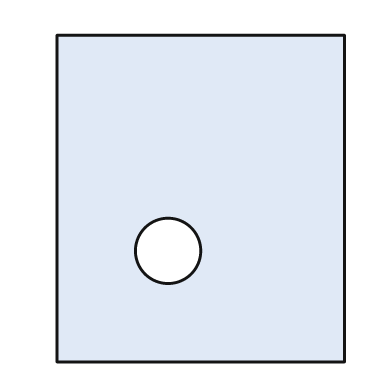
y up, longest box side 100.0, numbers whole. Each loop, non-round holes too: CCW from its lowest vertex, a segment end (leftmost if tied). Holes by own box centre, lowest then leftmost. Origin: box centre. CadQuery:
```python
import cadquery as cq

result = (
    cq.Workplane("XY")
    .moveTo(-44.0, -50.0)
    .lineTo(44.0, -50.0)
    .lineTo(44.0, 50.0)
    .lineTo(-44.0, 50.0)
    .close()
    .moveTo(-10.0, -16.0)
    .circle(10.0)
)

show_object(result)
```